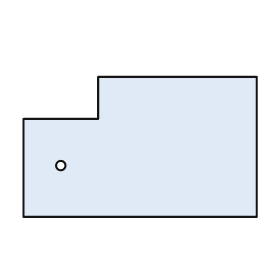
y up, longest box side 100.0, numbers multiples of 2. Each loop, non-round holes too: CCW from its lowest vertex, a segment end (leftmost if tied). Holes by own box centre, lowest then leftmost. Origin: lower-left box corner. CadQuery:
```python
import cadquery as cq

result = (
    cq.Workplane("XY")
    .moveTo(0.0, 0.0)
    .lineTo(100.0, 0.0)
    .lineTo(100.0, 60.0)
    .lineTo(32.0, 60.0)
    .lineTo(32.0, 42.0)
    .lineTo(0.0, 42.0)
    .close()
    .moveTo(16.0, 22.0)
    .circle(2.0)
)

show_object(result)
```